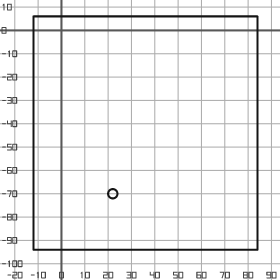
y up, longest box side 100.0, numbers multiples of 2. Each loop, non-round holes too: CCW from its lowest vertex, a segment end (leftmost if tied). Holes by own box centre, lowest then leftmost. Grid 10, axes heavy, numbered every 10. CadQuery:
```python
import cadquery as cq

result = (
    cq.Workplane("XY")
    .moveTo(-12.0, -94.0)
    .lineTo(84.0, -94.0)
    .lineTo(84.0, 6.0)
    .lineTo(-12.0, 6.0)
    .close()
    .moveTo(22.0, -70.0)
    .circle(2.0)
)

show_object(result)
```